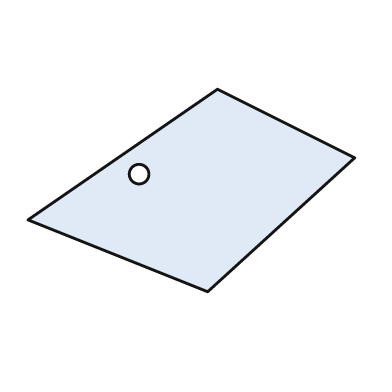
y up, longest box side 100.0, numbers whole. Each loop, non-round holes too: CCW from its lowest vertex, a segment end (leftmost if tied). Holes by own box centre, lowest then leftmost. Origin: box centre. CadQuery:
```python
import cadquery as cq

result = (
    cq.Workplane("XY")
    .moveTo(5.0, -31.0)
    .lineTo(50.0, 10.0)
    .lineTo(8.0, 31.0)
    .lineTo(-50.0, -9.0)
    .close()
    .moveTo(-16.0, 5.0)
    .circle(3.0)
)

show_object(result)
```